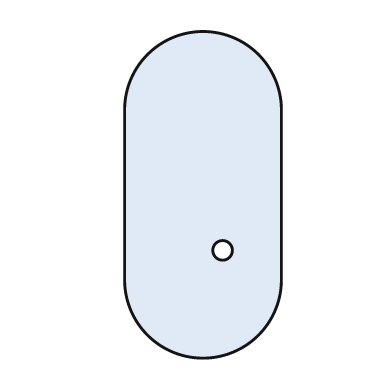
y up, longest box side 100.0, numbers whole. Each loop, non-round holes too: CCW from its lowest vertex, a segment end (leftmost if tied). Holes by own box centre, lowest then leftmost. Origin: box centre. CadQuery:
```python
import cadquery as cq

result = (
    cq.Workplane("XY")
    .moveTo(-24.0, -26.0)
    .threePointArc((0.0, -50.0), (24.0, -26.0))
    .lineTo(24.0, 26.0)
    .threePointArc((0.0, 50.0), (-24.0, 26.0))
    .close()
    .moveTo(6.0, -17.0)
    .circle(3.0)
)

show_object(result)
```